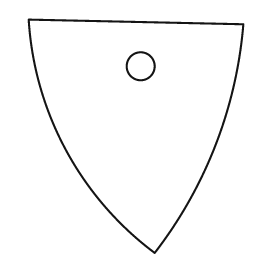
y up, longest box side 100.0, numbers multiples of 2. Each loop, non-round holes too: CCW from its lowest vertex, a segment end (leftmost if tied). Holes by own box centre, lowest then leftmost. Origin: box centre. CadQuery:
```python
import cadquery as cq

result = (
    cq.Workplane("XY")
    .moveTo(8.0, -50.0)
    .threePointArc((34.0, -4.0), (46.0, 48.0))
    .lineTo(-46.0, 50.0)
    .threePointArc((-30.0, -6.0), (8.0, -50.0))
    .close()
    .moveTo(2.0, 30.0)
    .circle(6.0)
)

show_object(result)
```